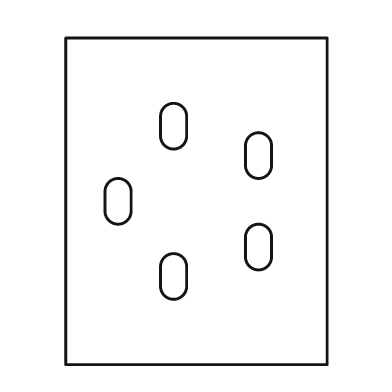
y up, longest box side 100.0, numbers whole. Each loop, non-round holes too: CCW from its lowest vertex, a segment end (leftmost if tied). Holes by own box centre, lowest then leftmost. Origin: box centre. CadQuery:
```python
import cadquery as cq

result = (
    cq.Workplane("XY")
    .moveTo(-40.0, -50.0)
    .lineTo(40.0, -50.0)
    .lineTo(40.0, 50.0)
    .lineTo(-40.0, 50.0)
    .close()
    .moveTo(-11.0, -26.0)
    .threePointArc((-7.0, -30.0), (-3.0, -26.0))
    .lineTo(-3.0, -20.0)
    .threePointArc((-7.0, -16.0), (-11.0, -20.0))
    .close()
    .moveTo(15.0, -17.0)
    .threePointArc((19.0, -21.0), (23.0, -17.0))
    .lineTo(23.0, -11.0)
    .threePointArc((19.0, -7.0), (15.0, -11.0))
    .close()
    .moveTo(-28.0, -3.0)
    .threePointArc((-24.0, -7.0), (-20.0, -3.0))
    .lineTo(-20.0, 3.0)
    .threePointArc((-24.0, 7.0), (-28.0, 3.0))
    .close()
    .moveTo(15.0, 11.0)
    .threePointArc((19.0, 7.0), (23.0, 11.0))
    .lineTo(23.0, 17.0)
    .threePointArc((19.0, 21.0), (15.0, 17.0))
    .close()
    .moveTo(-11.0, 20.0)
    .threePointArc((-7.0, 16.0), (-3.0, 20.0))
    .lineTo(-3.0, 26.0)
    .threePointArc((-7.0, 30.0), (-11.0, 26.0))
    .close()
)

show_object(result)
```